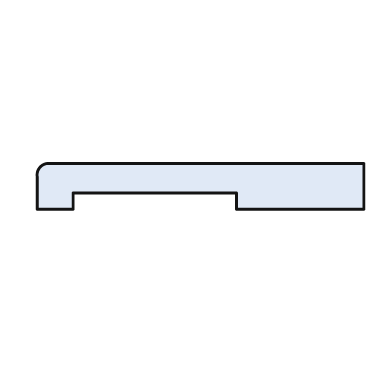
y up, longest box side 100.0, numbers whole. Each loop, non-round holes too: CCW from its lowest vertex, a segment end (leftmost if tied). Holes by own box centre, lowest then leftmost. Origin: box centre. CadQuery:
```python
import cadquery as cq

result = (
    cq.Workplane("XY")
    .moveTo(-50.0, -7.0)
    .lineTo(-39.0, -7.0)
    .lineTo(-39.0, -2.0)
    .lineTo(11.0, -2.0)
    .lineTo(11.0, -7.0)
    .lineTo(50.0, -7.0)
    .lineTo(50.0, 7.0)
    .lineTo(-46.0, 7.0)
    .threePointArc((-49.0, 6.0), (-50.0, 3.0))
    .close()
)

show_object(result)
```